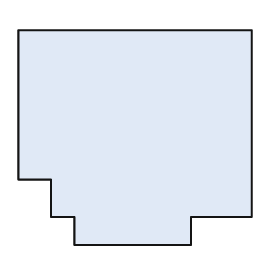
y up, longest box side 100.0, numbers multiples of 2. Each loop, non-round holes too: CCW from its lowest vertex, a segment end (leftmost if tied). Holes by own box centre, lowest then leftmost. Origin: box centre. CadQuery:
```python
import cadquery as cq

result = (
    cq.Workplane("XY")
    .moveTo(-26.0, -46.0)
    .lineTo(24.0, -46.0)
    .lineTo(24.0, -34.0)
    .lineTo(50.0, -34.0)
    .lineTo(50.0, 46.0)
    .lineTo(-50.0, 46.0)
    .lineTo(-50.0, -18.0)
    .lineTo(-36.0, -18.0)
    .lineTo(-36.0, -34.0)
    .lineTo(-26.0, -34.0)
    .close()
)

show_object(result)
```